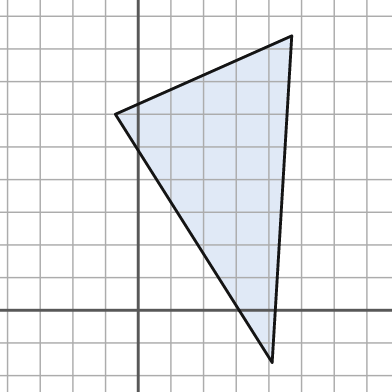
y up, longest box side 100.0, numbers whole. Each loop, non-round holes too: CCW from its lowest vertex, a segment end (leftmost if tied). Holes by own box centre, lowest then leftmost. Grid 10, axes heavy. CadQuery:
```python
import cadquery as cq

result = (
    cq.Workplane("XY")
    .moveTo(41.0, -16.0)
    .lineTo(47.0, 84.0)
    .lineTo(-7.0, 60.0)
    .close()
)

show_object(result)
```